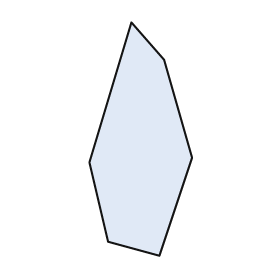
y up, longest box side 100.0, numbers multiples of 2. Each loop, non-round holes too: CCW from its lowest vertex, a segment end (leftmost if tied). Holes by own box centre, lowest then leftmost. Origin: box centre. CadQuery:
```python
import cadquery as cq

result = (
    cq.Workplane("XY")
    .moveTo(8.0, -50.0)
    .lineTo(22.0, -8.0)
    .lineTo(10.0, 34.0)
    .lineTo(-4.0, 50.0)
    .lineTo(-22.0, -10.0)
    .lineTo(-14.0, -44.0)
    .close()
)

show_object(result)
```